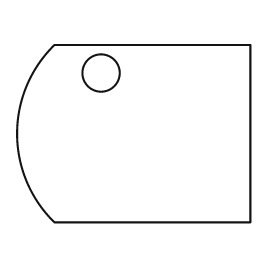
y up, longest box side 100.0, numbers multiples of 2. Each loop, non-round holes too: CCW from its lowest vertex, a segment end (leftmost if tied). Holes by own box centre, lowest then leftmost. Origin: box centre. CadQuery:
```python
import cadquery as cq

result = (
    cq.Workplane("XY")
    .moveTo(-34.0, -38.0)
    .lineTo(50.0, -38.0)
    .lineTo(50.0, 38.0)
    .lineTo(-34.0, 38.0)
    .threePointArc((-50.0, 0.0), (-34.0, -38.0))
    .close()
    .moveTo(-14.0, 26.0)
    .circle(8.0)
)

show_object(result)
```